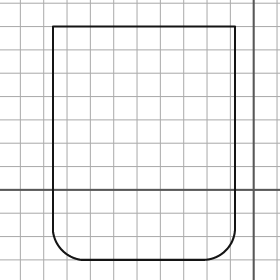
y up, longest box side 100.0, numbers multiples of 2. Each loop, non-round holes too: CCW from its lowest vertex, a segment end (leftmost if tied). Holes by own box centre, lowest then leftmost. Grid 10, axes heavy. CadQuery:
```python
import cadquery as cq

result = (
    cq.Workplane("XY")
    .moveTo(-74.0, -30.0)
    .lineTo(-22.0, -30.0)
    .threePointArc((-12.0, -26.0), (-8.0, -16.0))
    .lineTo(-8.0, 70.0)
    .lineTo(-86.0, 70.0)
    .lineTo(-86.0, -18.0)
    .threePointArc((-82.0, -26.0), (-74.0, -30.0))
    .close()
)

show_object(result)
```